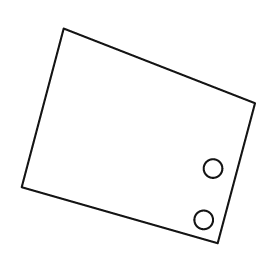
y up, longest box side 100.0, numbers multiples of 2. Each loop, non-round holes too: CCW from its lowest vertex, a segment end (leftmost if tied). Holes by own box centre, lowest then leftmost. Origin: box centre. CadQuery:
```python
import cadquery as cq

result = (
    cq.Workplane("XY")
    .moveTo(34.0, -46.0)
    .lineTo(50.0, 14.0)
    .lineTo(-32.0, 46.0)
    .lineTo(-50.0, -22.0)
    .close()
    .moveTo(28.0, -36.0)
    .circle(4.0)
    .moveTo(32.0, -14.0)
    .circle(4.0)
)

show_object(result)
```